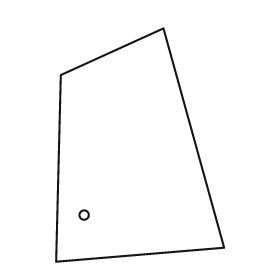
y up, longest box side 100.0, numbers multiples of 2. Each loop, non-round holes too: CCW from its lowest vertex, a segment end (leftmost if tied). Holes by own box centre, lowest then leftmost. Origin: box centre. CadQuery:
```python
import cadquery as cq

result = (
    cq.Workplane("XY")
    .moveTo(-36.0, -50.0)
    .lineTo(36.0, -44.0)
    .lineTo(10.0, 50.0)
    .lineTo(-34.0, 30.0)
    .close()
    .moveTo(-24.0, -30.0)
    .circle(2.0)
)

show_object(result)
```